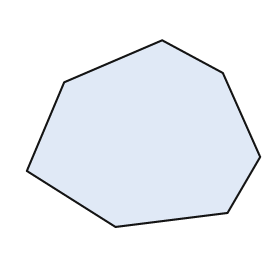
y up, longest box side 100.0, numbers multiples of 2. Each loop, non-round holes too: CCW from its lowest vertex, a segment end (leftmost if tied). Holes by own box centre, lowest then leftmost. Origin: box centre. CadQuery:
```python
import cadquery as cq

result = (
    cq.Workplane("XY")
    .moveTo(-12.0, -40.0)
    .lineTo(36.0, -34.0)
    .lineTo(50.0, -10.0)
    .lineTo(34.0, 26.0)
    .lineTo(8.0, 40.0)
    .lineTo(-34.0, 22.0)
    .lineTo(-50.0, -16.0)
    .close()
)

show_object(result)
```